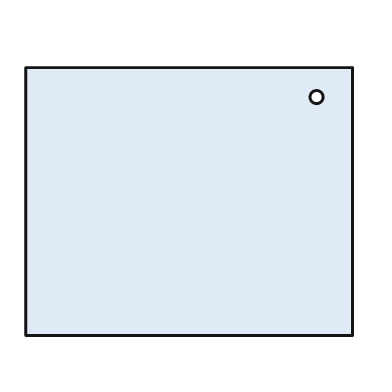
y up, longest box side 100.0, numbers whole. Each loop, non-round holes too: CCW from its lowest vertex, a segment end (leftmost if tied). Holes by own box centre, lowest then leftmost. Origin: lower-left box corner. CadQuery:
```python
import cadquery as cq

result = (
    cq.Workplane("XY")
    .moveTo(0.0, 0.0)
    .lineTo(100.0, 0.0)
    .lineTo(100.0, 82.0)
    .lineTo(0.0, 82.0)
    .close()
    .moveTo(89.0, 73.0)
    .circle(2.0)
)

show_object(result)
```